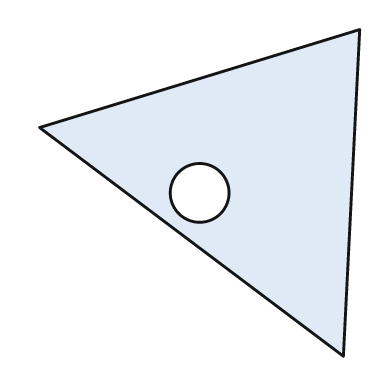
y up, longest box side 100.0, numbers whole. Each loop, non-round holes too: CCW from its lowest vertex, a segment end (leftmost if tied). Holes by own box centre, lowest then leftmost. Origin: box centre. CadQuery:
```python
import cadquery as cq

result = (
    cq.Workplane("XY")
    .moveTo(44.0, -50.0)
    .lineTo(49.0, 50.0)
    .lineTo(-49.0, 20.0)
    .close()
    .moveTo(0.0, 0.0)
    .circle(9.0)
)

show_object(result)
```